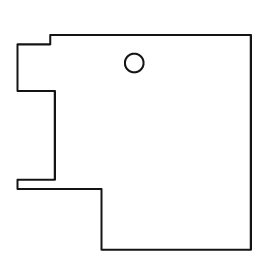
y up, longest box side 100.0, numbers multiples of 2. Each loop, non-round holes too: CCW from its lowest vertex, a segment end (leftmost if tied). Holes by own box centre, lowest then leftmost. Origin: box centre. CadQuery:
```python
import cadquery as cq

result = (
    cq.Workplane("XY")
    .moveTo(-14.0, -46.0)
    .lineTo(50.0, -46.0)
    .lineTo(50.0, 46.0)
    .lineTo(-36.0, 46.0)
    .lineTo(-36.0, 42.0)
    .lineTo(-50.0, 42.0)
    .lineTo(-50.0, 22.0)
    .lineTo(-34.0, 22.0)
    .lineTo(-34.0, -16.0)
    .lineTo(-50.0, -16.0)
    .lineTo(-50.0, -20.0)
    .lineTo(-14.0, -20.0)
    .close()
    .moveTo(0.0, 34.0)
    .circle(4.0)
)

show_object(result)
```